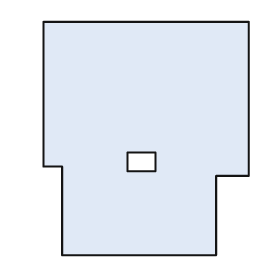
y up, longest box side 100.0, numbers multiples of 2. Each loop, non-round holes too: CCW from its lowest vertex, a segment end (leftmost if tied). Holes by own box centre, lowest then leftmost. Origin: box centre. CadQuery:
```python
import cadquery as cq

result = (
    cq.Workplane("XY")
    .moveTo(-36.0, -50.0)
    .lineTo(30.0, -50.0)
    .lineTo(30.0, -16.0)
    .lineTo(44.0, -16.0)
    .lineTo(44.0, 50.0)
    .lineTo(-44.0, 50.0)
    .lineTo(-44.0, -12.0)
    .lineTo(-36.0, -12.0)
    .close()
    .moveTo(-8.0, -14.0)
    .lineTo(4.0, -14.0)
    .lineTo(4.0, -6.0)
    .lineTo(-8.0, -6.0)
    .close()
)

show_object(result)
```